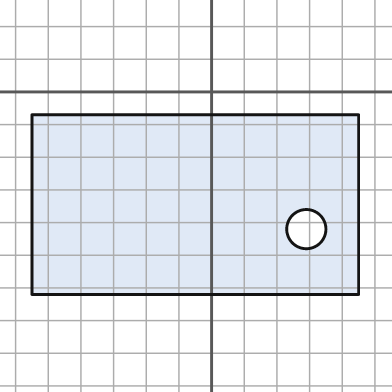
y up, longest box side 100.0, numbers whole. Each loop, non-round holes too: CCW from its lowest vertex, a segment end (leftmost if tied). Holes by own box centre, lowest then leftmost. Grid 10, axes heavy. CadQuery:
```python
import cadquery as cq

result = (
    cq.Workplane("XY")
    .moveTo(-55.0, -62.0)
    .lineTo(45.0, -62.0)
    .lineTo(45.0, -7.0)
    .lineTo(-55.0, -7.0)
    .close()
    .moveTo(29.0, -42.0)
    .circle(6.0)
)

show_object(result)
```